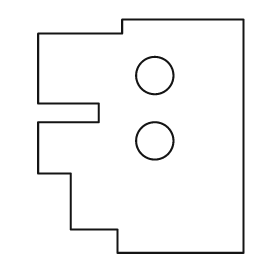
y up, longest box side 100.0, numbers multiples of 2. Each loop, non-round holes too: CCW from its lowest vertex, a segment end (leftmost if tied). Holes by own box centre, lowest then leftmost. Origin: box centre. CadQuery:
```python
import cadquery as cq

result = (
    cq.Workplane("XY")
    .moveTo(-10.0, -50.0)
    .lineTo(44.0, -50.0)
    .lineTo(44.0, 50.0)
    .lineTo(-8.0, 50.0)
    .lineTo(-8.0, 44.0)
    .lineTo(-44.0, 44.0)
    .lineTo(-44.0, 14.0)
    .lineTo(-18.0, 14.0)
    .lineTo(-18.0, 6.0)
    .lineTo(-44.0, 6.0)
    .lineTo(-44.0, -16.0)
    .lineTo(-30.0, -16.0)
    .lineTo(-30.0, -40.0)
    .lineTo(-10.0, -40.0)
    .close()
    .moveTo(6.0, -2.0)
    .circle(8.0)
    .moveTo(6.0, 26.0)
    .circle(8.0)
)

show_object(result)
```